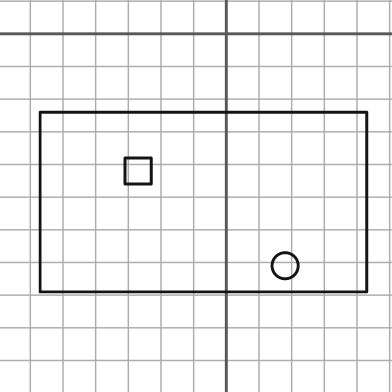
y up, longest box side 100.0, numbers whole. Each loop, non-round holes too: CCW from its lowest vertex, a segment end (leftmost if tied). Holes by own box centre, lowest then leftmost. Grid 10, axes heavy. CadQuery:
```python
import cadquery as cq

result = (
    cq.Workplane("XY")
    .moveTo(-57.0, -79.0)
    .lineTo(43.0, -79.0)
    .lineTo(43.0, -24.0)
    .lineTo(-57.0, -24.0)
    .close()
    .moveTo(18.0, -71.0)
    .circle(4.0)
    .moveTo(-31.0, -46.0)
    .lineTo(-23.0, -46.0)
    .lineTo(-23.0, -38.0)
    .lineTo(-31.0, -38.0)
    .close()
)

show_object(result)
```